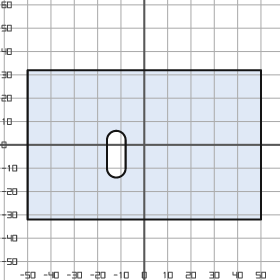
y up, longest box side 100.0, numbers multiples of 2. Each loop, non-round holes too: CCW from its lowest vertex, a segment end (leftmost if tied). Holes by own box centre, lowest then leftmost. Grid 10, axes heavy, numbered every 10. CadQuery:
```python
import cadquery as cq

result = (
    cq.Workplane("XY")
    .moveTo(-50.0, -32.0)
    .lineTo(50.0, -32.0)
    .lineTo(50.0, 32.0)
    .lineTo(-50.0, 32.0)
    .close()
    .moveTo(-16.0, -10.0)
    .threePointArc((-12.0, -14.0), (-8.0, -10.0))
    .lineTo(-8.0, 2.0)
    .threePointArc((-12.0, 6.0), (-16.0, 2.0))
    .close()
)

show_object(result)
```